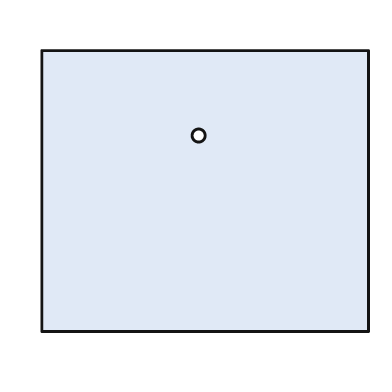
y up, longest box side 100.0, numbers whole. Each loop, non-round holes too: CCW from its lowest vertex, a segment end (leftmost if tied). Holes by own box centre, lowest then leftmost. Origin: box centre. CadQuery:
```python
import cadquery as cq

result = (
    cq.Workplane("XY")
    .moveTo(-50.0, -43.0)
    .lineTo(50.0, -43.0)
    .lineTo(50.0, 43.0)
    .lineTo(-50.0, 43.0)
    .close()
    .moveTo(-2.0, 17.0)
    .circle(2.0)
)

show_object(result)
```